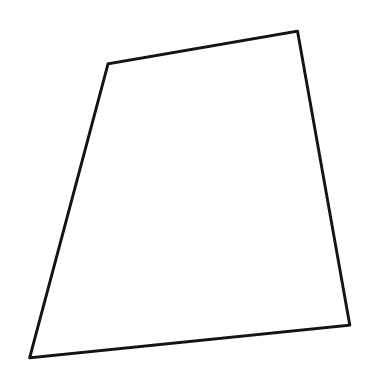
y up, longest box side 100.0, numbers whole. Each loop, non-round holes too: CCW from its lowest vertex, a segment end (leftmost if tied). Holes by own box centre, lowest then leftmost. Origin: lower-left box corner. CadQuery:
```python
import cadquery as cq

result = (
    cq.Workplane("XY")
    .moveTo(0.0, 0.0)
    .lineTo(98.0, 10.0)
    .lineTo(82.0, 100.0)
    .lineTo(24.0, 90.0)
    .close()
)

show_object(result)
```